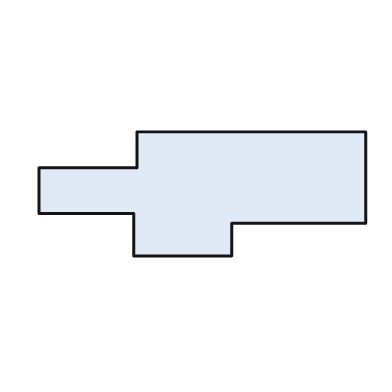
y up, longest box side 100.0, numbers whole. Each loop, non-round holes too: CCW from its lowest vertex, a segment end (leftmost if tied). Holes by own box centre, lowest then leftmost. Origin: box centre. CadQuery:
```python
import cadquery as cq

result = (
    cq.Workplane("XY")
    .moveTo(-21.0, -19.0)
    .lineTo(9.0, -19.0)
    .lineTo(9.0, -9.0)
    .lineTo(50.0, -9.0)
    .lineTo(50.0, 19.0)
    .lineTo(-20.0, 19.0)
    .lineTo(-20.0, 8.0)
    .lineTo(-50.0, 8.0)
    .lineTo(-50.0, -6.0)
    .lineTo(-21.0, -6.0)
    .close()
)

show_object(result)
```